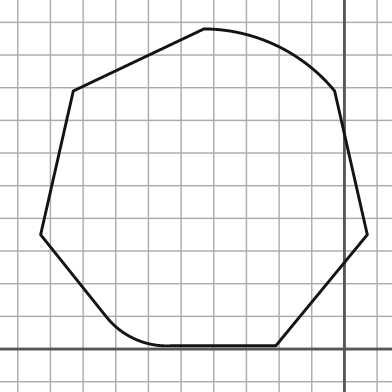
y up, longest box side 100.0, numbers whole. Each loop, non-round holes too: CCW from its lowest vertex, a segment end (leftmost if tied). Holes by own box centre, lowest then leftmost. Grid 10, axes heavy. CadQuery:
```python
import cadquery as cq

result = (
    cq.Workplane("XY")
    .moveTo(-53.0, 1.0)
    .lineTo(-21.0, 1.0)
    .lineTo(7.0, 35.0)
    .lineTo(-3.0, 79.0)
    .threePointArc((-21.0, 93.0), (-43.0, 98.0))
    .lineTo(-83.0, 79.0)
    .lineTo(-93.0, 35.0)
    .lineTo(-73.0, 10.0)
    .threePointArc((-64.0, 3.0), (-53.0, 1.0))
    .close()
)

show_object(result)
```